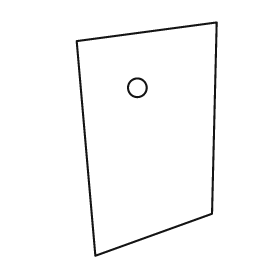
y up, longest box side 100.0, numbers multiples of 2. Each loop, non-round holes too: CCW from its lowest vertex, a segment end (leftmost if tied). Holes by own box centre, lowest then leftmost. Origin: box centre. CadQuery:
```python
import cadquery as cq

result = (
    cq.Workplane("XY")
    .moveTo(-22.0, -50.0)
    .lineTo(28.0, -32.0)
    .lineTo(30.0, 50.0)
    .lineTo(-30.0, 42.0)
    .close()
    .moveTo(-4.0, 22.0)
    .circle(4.0)
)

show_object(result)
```